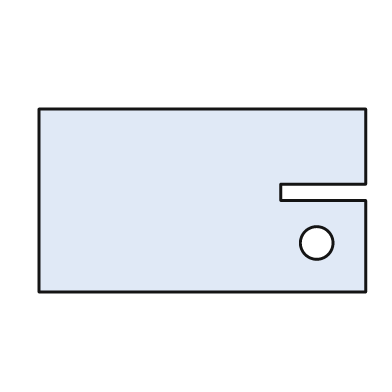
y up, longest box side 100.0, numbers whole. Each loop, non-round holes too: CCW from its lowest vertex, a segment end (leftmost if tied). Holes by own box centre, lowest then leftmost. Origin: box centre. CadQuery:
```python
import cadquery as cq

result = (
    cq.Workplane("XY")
    .moveTo(-50.0, -28.0)
    .lineTo(50.0, -28.0)
    .lineTo(50.0, 0.0)
    .lineTo(24.0, 0.0)
    .lineTo(24.0, 5.0)
    .lineTo(50.0, 5.0)
    .lineTo(50.0, 28.0)
    .lineTo(-50.0, 28.0)
    .close()
    .moveTo(35.0, -13.0)
    .circle(5.0)
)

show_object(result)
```